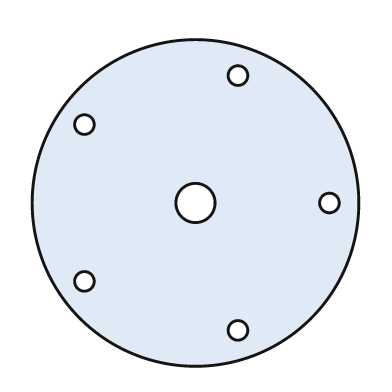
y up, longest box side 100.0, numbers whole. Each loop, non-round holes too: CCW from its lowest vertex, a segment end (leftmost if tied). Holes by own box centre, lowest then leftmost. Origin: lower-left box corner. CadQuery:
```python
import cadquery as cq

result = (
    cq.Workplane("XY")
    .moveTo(50.0, 50.0)
    .circle(50.0)
    .moveTo(63.0, 11.0)
    .circle(3.0)
    .moveTo(16.0, 26.0)
    .circle(3.0)
    .moveTo(50.0, 50.0)
    .circle(6.0)
    .moveTo(91.0, 50.0)
    .circle(3.0)
    .moveTo(16.0, 74.0)
    .circle(3.0)
    .moveTo(63.0, 89.0)
    .circle(3.0)
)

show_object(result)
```